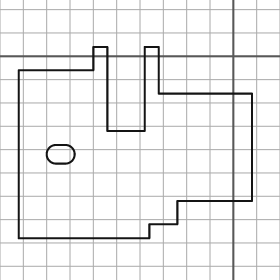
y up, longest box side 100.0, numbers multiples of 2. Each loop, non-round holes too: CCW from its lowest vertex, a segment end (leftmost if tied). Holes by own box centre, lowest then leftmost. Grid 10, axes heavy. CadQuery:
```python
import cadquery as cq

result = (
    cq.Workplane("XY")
    .moveTo(-92.0, -78.0)
    .lineTo(-36.0, -78.0)
    .lineTo(-36.0, -72.0)
    .lineTo(-24.0, -72.0)
    .lineTo(-24.0, -62.0)
    .lineTo(8.0, -62.0)
    .lineTo(8.0, -16.0)
    .lineTo(-32.0, -16.0)
    .lineTo(-32.0, 4.0)
    .lineTo(-38.0, 4.0)
    .lineTo(-38.0, -32.0)
    .lineTo(-54.0, -32.0)
    .lineTo(-54.0, 4.0)
    .lineTo(-60.0, 4.0)
    .lineTo(-60.0, -6.0)
    .lineTo(-92.0, -6.0)
    .close()
    .moveTo(-76.0, -46.0)
    .lineTo(-72.0, -46.0)
    .threePointArc((-68.0, -42.0), (-72.0, -38.0))
    .lineTo(-76.0, -38.0)
    .threePointArc((-80.0, -42.0), (-76.0, -46.0))
    .close()
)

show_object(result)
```